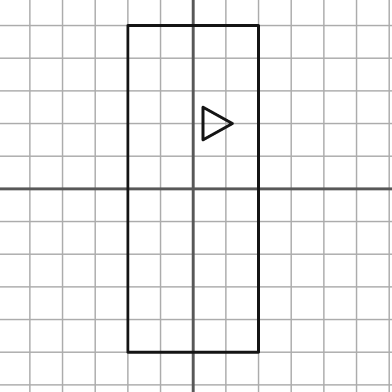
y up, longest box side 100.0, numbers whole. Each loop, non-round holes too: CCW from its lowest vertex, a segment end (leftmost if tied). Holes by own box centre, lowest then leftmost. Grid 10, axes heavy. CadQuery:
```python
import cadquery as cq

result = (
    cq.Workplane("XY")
    .moveTo(-20.0, -50.0)
    .lineTo(20.0, -50.0)
    .lineTo(20.0, 50.0)
    .lineTo(-20.0, 50.0)
    .close()
    .moveTo(3.0, 15.0)
    .lineTo(12.0, 20.0)
    .lineTo(3.0, 25.0)
    .close()
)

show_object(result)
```